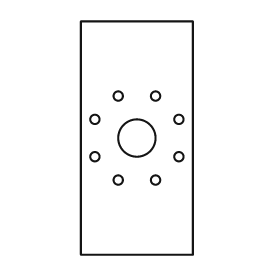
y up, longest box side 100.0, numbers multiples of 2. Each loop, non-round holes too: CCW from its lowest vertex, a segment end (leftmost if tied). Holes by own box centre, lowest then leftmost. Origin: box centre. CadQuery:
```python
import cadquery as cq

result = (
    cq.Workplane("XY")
    .moveTo(-24.0, -50.0)
    .lineTo(24.0, -50.0)
    .lineTo(24.0, 50.0)
    .lineTo(-24.0, 50.0)
    .close()
    .moveTo(-8.0, -18.0)
    .circle(2.0)
    .moveTo(8.0, -18.0)
    .circle(2.0)
    .moveTo(-18.0, -8.0)
    .circle(2.0)
    .moveTo(18.0, -8.0)
    .circle(2.0)
    .moveTo(0.0, 0.0)
    .circle(8.0)
    .moveTo(-18.0, 8.0)
    .circle(2.0)
    .moveTo(18.0, 8.0)
    .circle(2.0)
    .moveTo(-8.0, 18.0)
    .circle(2.0)
    .moveTo(8.0, 18.0)
    .circle(2.0)
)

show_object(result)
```